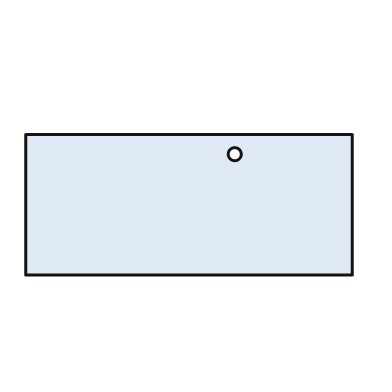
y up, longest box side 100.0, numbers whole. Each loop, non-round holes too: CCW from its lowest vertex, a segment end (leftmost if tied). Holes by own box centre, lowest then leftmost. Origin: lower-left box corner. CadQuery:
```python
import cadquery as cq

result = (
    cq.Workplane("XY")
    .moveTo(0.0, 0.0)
    .lineTo(100.0, 0.0)
    .lineTo(100.0, 43.0)
    .lineTo(0.0, 43.0)
    .close()
    .moveTo(64.0, 37.0)
    .circle(2.0)
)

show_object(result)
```